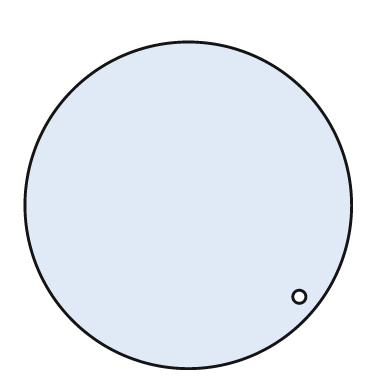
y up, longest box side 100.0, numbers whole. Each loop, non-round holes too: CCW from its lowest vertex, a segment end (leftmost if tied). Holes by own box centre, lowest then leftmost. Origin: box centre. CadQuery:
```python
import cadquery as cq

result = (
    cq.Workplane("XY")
    .moveTo(0.0, 0.0)
    .circle(50.0)
    .moveTo(34.0, -28.0)
    .circle(2.0)
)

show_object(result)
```